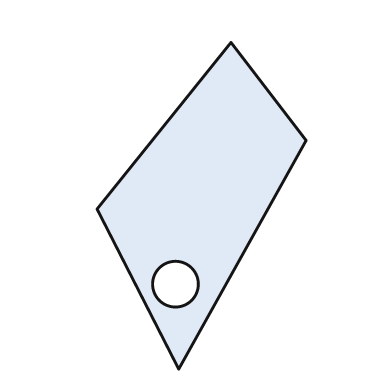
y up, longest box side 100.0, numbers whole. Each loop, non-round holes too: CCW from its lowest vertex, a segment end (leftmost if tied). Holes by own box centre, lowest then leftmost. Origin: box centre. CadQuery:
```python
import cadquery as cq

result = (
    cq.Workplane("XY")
    .moveTo(-7.0, -50.0)
    .lineTo(32.0, 20.0)
    .lineTo(9.0, 50.0)
    .lineTo(-32.0, -1.0)
    .close()
    .moveTo(-8.0, -24.0)
    .circle(7.0)
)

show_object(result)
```